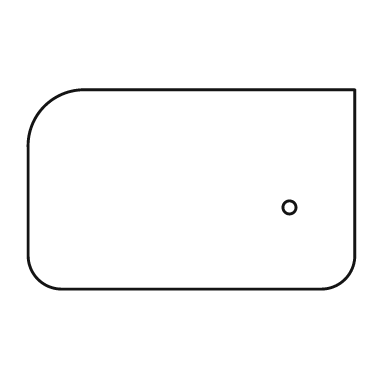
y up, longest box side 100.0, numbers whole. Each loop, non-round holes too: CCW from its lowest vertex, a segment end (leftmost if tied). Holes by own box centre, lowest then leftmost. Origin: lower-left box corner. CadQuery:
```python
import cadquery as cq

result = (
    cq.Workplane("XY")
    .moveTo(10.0, 0.0)
    .lineTo(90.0, 0.0)
    .threePointArc((97.0, 3.0), (100.0, 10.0))
    .lineTo(100.0, 61.0)
    .lineTo(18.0, 61.0)
    .threePointArc((5.0, 56.0), (0.0, 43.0))
    .lineTo(0.0, 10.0)
    .threePointArc((3.0, 3.0), (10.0, 0.0))
    .close()
    .moveTo(80.0, 25.0)
    .circle(2.0)
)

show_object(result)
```